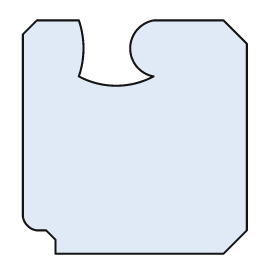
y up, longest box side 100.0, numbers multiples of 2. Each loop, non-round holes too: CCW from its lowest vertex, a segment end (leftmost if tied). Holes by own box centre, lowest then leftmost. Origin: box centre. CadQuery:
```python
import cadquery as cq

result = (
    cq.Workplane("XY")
    .moveTo(-34.0, -50.0)
    .lineTo(38.0, -50.0)
    .lineTo(48.0, -40.0)
    .lineTo(48.0, 40.0)
    .lineTo(38.0, 50.0)
    .lineTo(8.0, 50.0)
    .threePointArc((-2.0, 38.0), (8.0, 26.0))
    .threePointArc((-8.0, 22.0), (-24.0, 26.0))
    .threePointArc((-22.0, 38.0), (-24.0, 50.0))
    .lineTo(-42.0, 50.0)
    .lineTo(-48.0, 44.0)
    .lineTo(-48.0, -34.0)
    .threePointArc((-46.0, -38.0), (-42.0, -40.0))
    .lineTo(-38.0, -40.0)
    .lineTo(-34.0, -44.0)
    .close()
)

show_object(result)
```